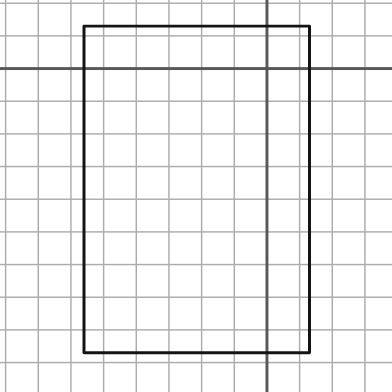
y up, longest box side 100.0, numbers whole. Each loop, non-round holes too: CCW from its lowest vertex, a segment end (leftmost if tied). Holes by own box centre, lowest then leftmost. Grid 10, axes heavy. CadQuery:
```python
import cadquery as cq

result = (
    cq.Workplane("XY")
    .moveTo(-56.0, -87.0)
    .lineTo(13.0, -87.0)
    .lineTo(13.0, 13.0)
    .lineTo(-56.0, 13.0)
    .close()
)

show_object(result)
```